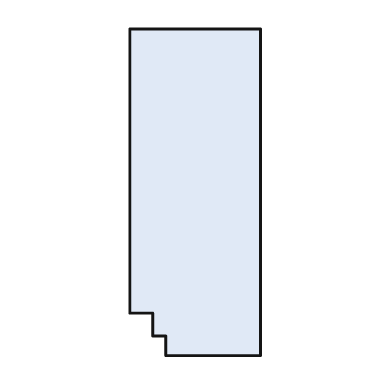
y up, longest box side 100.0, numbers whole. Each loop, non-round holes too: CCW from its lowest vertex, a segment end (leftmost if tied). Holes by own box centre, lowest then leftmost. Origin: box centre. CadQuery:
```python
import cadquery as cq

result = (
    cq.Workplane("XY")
    .moveTo(-9.0, -50.0)
    .lineTo(20.0, -50.0)
    .lineTo(20.0, 50.0)
    .lineTo(-20.0, 50.0)
    .lineTo(-20.0, -37.0)
    .lineTo(-13.0, -37.0)
    .lineTo(-13.0, -44.0)
    .lineTo(-9.0, -44.0)
    .close()
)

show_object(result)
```